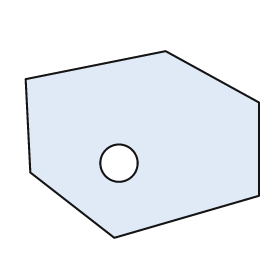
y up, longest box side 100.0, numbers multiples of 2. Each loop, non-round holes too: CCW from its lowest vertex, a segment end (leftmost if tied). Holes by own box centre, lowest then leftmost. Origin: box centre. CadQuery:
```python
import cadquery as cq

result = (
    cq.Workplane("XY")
    .moveTo(-12.0, -40.0)
    .lineTo(50.0, -22.0)
    .lineTo(50.0, 18.0)
    .lineTo(10.0, 40.0)
    .lineTo(-50.0, 28.0)
    .lineTo(-48.0, -12.0)
    .close()
    .moveTo(-10.0, -8.0)
    .circle(8.0)
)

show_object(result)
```